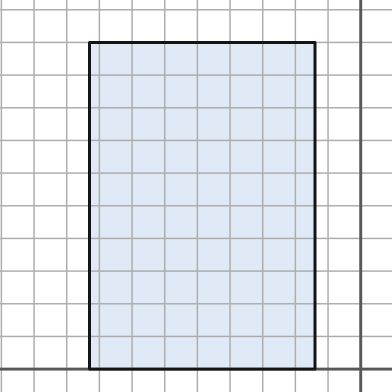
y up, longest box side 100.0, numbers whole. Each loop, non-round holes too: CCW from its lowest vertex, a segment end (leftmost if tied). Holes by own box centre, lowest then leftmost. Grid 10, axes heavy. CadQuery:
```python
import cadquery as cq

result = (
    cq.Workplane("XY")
    .moveTo(-83.0, 0.0)
    .lineTo(-14.0, 0.0)
    .lineTo(-14.0, 100.0)
    .lineTo(-83.0, 100.0)
    .close()
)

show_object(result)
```